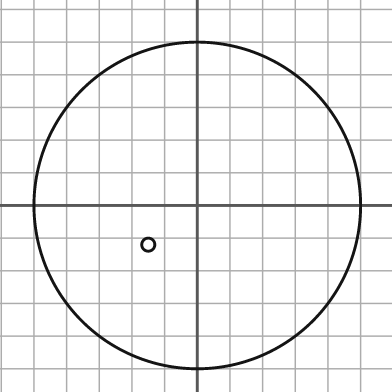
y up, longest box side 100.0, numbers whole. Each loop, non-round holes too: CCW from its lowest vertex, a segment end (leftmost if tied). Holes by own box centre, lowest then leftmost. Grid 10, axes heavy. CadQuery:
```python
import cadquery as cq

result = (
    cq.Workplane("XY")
    .moveTo(0.0, 0.0)
    .circle(50.0)
    .moveTo(-15.0, -12.0)
    .circle(2.0)
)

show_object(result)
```